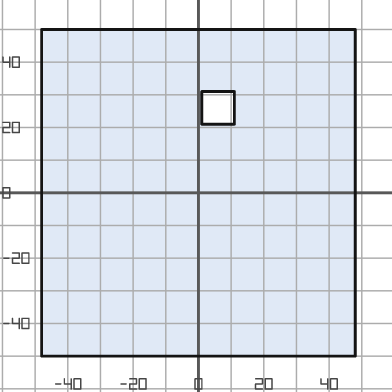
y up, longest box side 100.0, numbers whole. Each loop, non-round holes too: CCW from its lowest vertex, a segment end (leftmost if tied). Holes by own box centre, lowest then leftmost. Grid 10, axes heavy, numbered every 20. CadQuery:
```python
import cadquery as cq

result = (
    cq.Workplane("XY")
    .moveTo(-48.0, -50.0)
    .lineTo(48.0, -50.0)
    .lineTo(48.0, 50.0)
    .lineTo(-48.0, 50.0)
    .close()
    .moveTo(1.0, 21.0)
    .lineTo(11.0, 21.0)
    .lineTo(11.0, 31.0)
    .lineTo(1.0, 31.0)
    .close()
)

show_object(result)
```